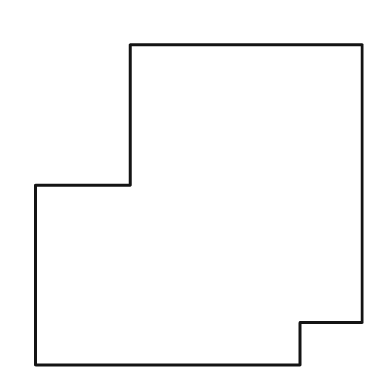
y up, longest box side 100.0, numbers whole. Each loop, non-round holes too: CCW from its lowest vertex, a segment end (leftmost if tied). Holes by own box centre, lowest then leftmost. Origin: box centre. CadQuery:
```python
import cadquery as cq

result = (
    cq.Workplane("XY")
    .moveTo(-50.0, -49.0)
    .lineTo(31.0, -49.0)
    .lineTo(31.0, -36.0)
    .lineTo(50.0, -36.0)
    .lineTo(50.0, 49.0)
    .lineTo(-21.0, 49.0)
    .lineTo(-21.0, 6.0)
    .lineTo(-50.0, 6.0)
    .close()
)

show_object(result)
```